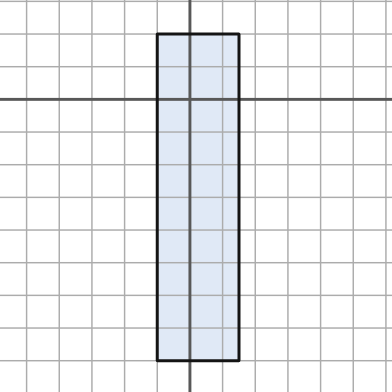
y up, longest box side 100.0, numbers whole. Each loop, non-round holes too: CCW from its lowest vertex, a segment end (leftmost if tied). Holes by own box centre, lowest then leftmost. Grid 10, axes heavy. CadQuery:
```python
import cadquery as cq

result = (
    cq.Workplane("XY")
    .moveTo(-10.0, -80.0)
    .lineTo(15.0, -80.0)
    .lineTo(15.0, 20.0)
    .lineTo(-10.0, 20.0)
    .close()
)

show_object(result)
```